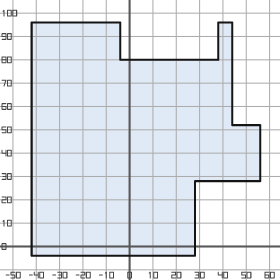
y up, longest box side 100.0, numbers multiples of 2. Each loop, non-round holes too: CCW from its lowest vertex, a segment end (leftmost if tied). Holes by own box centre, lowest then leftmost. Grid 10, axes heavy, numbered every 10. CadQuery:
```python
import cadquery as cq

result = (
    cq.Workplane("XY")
    .moveTo(-42.0, -4.0)
    .lineTo(28.0, -4.0)
    .lineTo(28.0, 28.0)
    .lineTo(56.0, 28.0)
    .lineTo(56.0, 52.0)
    .lineTo(44.0, 52.0)
    .lineTo(44.0, 96.0)
    .lineTo(38.0, 96.0)
    .lineTo(38.0, 80.0)
    .lineTo(-4.0, 80.0)
    .lineTo(-4.0, 96.0)
    .lineTo(-42.0, 96.0)
    .close()
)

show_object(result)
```